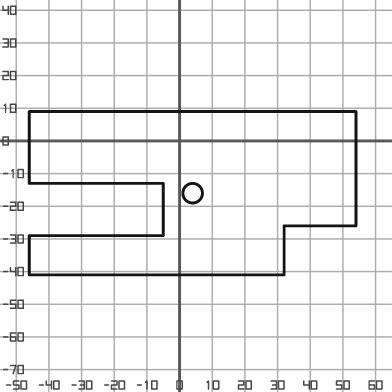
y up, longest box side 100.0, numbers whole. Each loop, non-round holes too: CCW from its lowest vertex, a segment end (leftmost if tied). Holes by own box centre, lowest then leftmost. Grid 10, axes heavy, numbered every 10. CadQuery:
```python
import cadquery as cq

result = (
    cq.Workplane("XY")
    .moveTo(-46.0, -41.0)
    .lineTo(32.0, -41.0)
    .lineTo(32.0, -26.0)
    .lineTo(54.0, -26.0)
    .lineTo(54.0, 9.0)
    .lineTo(-46.0, 9.0)
    .lineTo(-46.0, -13.0)
    .lineTo(-5.0, -13.0)
    .lineTo(-5.0, -29.0)
    .lineTo(-46.0, -29.0)
    .close()
    .moveTo(4.0, -16.0)
    .circle(3.0)
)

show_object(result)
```